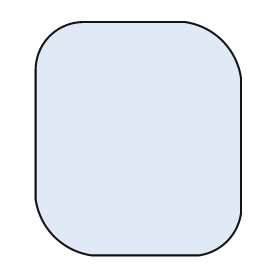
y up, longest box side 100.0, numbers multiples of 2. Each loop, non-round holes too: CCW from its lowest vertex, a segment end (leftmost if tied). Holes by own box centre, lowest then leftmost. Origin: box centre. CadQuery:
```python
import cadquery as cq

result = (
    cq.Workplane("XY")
    .moveTo(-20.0, -50.0)
    .lineTo(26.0, -50.0)
    .threePointArc((38.0, -44.0), (44.0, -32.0))
    .lineTo(44.0, 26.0)
    .threePointArc((36.0, 42.0), (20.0, 50.0))
    .lineTo(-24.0, 50.0)
    .threePointArc((-38.0, 44.0), (-44.0, 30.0))
    .lineTo(-44.0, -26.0)
    .threePointArc((-36.0, -42.0), (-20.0, -50.0))
    .close()
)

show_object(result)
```